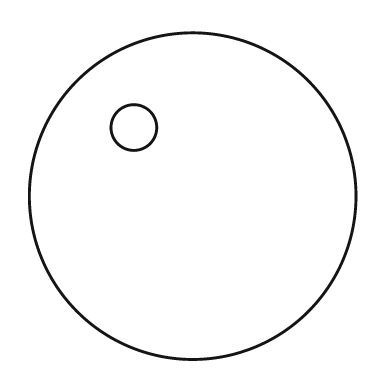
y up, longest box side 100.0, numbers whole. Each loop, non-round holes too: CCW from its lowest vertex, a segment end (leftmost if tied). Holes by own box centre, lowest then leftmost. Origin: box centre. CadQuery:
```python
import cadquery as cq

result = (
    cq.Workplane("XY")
    .moveTo(0.0, 0.0)
    .circle(50.0)
    .moveTo(-18.0, 21.0)
    .circle(7.0)
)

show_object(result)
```